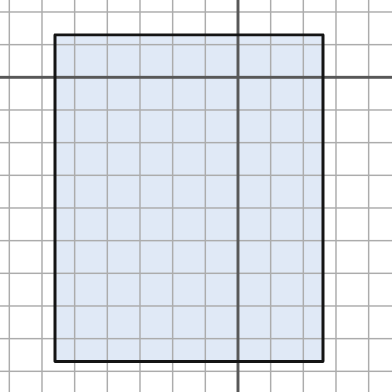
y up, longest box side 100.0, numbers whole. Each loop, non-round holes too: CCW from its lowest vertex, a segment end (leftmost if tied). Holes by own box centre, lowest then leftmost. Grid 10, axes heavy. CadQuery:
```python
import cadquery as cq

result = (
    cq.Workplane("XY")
    .moveTo(-56.0, -87.0)
    .lineTo(26.0, -87.0)
    .lineTo(26.0, 13.0)
    .lineTo(-56.0, 13.0)
    .close()
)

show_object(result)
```